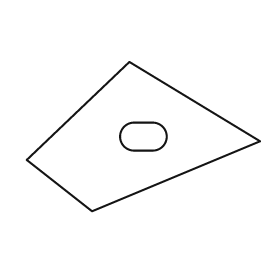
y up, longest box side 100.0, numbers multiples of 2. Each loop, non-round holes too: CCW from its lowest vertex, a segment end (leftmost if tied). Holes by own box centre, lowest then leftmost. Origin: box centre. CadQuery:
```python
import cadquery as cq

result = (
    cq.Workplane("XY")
    .moveTo(-22.0, -32.0)
    .lineTo(50.0, -2.0)
    .lineTo(-6.0, 32.0)
    .lineTo(-50.0, -10.0)
    .close()
    .moveTo(-4.0, -6.0)
    .lineTo(4.0, -6.0)
    .threePointArc((10.0, 0.0), (4.0, 6.0))
    .lineTo(-4.0, 6.0)
    .threePointArc((-10.0, 0.0), (-4.0, -6.0))
    .close()
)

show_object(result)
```